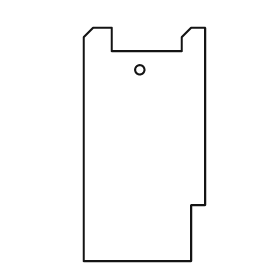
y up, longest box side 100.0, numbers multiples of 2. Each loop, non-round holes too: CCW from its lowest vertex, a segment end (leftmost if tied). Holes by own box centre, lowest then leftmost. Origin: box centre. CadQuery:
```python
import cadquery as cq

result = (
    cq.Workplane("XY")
    .moveTo(-26.0, -50.0)
    .lineTo(20.0, -50.0)
    .lineTo(20.0, -26.0)
    .lineTo(26.0, -26.0)
    .lineTo(26.0, 50.0)
    .lineTo(20.0, 50.0)
    .lineTo(16.0, 46.0)
    .lineTo(16.0, 40.0)
    .lineTo(-14.0, 40.0)
    .lineTo(-14.0, 50.0)
    .lineTo(-22.0, 50.0)
    .lineTo(-26.0, 46.0)
    .close()
    .moveTo(-2.0, 32.0)
    .circle(2.0)
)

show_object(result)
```